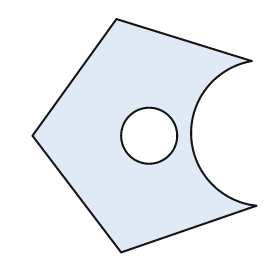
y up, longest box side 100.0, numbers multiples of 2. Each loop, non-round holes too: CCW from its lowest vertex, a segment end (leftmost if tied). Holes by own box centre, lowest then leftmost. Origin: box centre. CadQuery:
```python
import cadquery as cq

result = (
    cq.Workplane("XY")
    .moveTo(-10.0, -50.0)
    .lineTo(48.0, -30.0)
    .threePointArc((20.0, 0.0), (46.0, 32.0))
    .lineTo(-12.0, 50.0)
    .lineTo(-48.0, 0.0)
    .close()
    .moveTo(2.0, 0.0)
    .circle(12.0)
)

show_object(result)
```